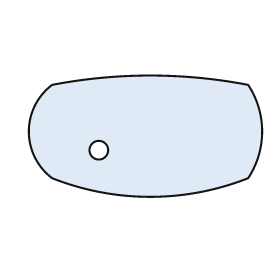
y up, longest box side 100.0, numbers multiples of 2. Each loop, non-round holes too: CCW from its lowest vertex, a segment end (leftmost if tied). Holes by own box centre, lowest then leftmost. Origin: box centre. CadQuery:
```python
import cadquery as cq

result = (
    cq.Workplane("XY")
    .moveTo(-40.0, -18.0)
    .threePointArc((2.0, -26.0), (44.0, -18.0))
    .threePointArc((50.0, 2.0), (44.0, 22.0))
    .threePointArc((2.0, 26.0), (-40.0, 22.0))
    .threePointArc((-50.0, 2.0), (-40.0, -18.0))
    .close()
    .moveTo(-20.0, -6.0)
    .circle(4.0)
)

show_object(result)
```